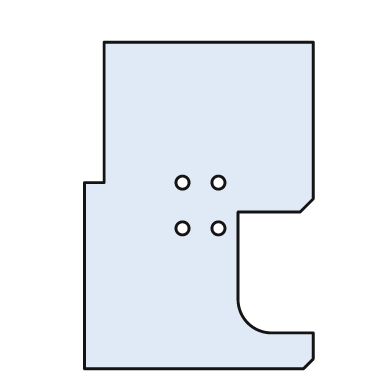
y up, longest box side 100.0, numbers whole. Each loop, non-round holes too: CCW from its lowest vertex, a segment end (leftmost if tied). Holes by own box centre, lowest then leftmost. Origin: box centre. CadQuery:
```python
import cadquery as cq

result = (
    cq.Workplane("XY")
    .moveTo(-35.0, -50.0)
    .lineTo(32.0, -50.0)
    .lineTo(35.0, -47.0)
    .lineTo(35.0, -39.0)
    .lineTo(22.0, -39.0)
    .threePointArc((15.0, -36.0), (12.0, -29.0))
    .lineTo(12.0, -2.0)
    .lineTo(31.0, -2.0)
    .lineTo(35.0, 2.0)
    .lineTo(35.0, 50.0)
    .lineTo(-29.0, 50.0)
    .lineTo(-29.0, 7.0)
    .lineTo(-35.0, 7.0)
    .close()
    .moveTo(-5.0, -7.0)
    .circle(2.0)
    .moveTo(6.0, -7.0)
    .circle(2.0)
    .moveTo(-5.0, 7.0)
    .circle(2.0)
    .moveTo(6.0, 7.0)
    .circle(2.0)
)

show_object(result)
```